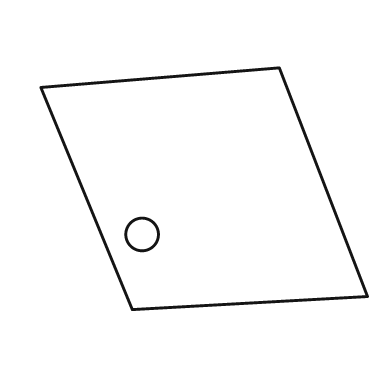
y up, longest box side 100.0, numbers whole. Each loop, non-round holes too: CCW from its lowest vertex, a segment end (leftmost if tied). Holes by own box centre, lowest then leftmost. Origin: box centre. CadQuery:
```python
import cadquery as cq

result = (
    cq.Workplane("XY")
    .moveTo(-22.0, -37.0)
    .lineTo(50.0, -33.0)
    .lineTo(23.0, 37.0)
    .lineTo(-50.0, 31.0)
    .close()
    .moveTo(-19.0, -14.0)
    .circle(5.0)
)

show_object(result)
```